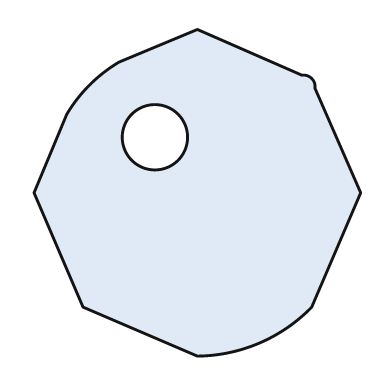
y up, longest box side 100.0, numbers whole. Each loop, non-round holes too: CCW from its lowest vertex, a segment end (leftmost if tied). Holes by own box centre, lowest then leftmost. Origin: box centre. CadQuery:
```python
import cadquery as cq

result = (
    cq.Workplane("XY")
    .moveTo(0.0, -50.0)
    .threePointArc((19.0, -46.0), (35.0, -35.0))
    .lineTo(50.0, 0.0)
    .lineTo(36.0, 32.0)
    .threePointArc((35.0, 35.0), (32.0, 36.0))
    .lineTo(0.0, 50.0)
    .lineTo(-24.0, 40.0)
    .threePointArc((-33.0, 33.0), (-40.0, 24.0))
    .lineTo(-50.0, 0.0)
    .lineTo(-35.0, -35.0)
    .close()
    .moveTo(-13.0, 17.0)
    .circle(10.0)
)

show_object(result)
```